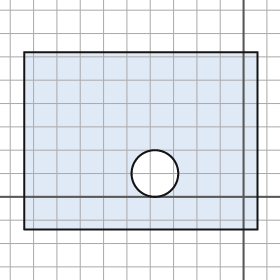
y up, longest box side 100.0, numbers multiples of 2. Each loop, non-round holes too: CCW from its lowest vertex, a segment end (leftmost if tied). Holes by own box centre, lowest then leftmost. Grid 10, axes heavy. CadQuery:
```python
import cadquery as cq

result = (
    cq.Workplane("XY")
    .moveTo(-94.0, -14.0)
    .lineTo(6.0, -14.0)
    .lineTo(6.0, 62.0)
    .lineTo(-94.0, 62.0)
    .close()
    .moveTo(-38.0, 10.0)
    .circle(10.0)
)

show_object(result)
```